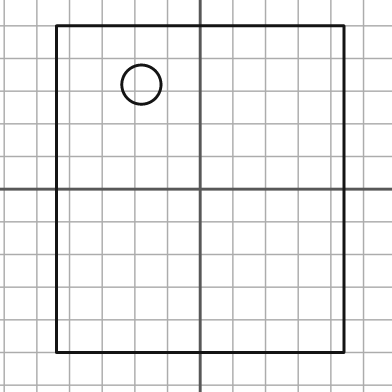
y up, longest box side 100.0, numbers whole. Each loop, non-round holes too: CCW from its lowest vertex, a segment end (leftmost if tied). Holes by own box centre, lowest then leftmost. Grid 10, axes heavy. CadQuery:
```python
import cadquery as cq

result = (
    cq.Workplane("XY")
    .moveTo(-44.0, -50.0)
    .lineTo(44.0, -50.0)
    .lineTo(44.0, 50.0)
    .lineTo(-44.0, 50.0)
    .close()
    .moveTo(-18.0, 32.0)
    .circle(6.0)
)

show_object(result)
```